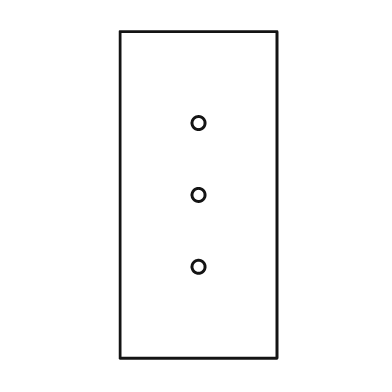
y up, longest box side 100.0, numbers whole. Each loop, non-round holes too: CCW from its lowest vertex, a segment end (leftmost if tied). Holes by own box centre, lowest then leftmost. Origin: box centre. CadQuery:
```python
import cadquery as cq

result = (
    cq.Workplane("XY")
    .moveTo(-24.0, -50.0)
    .lineTo(24.0, -50.0)
    .lineTo(24.0, 50.0)
    .lineTo(-24.0, 50.0)
    .close()
    .moveTo(0.0, -22.0)
    .circle(2.0)
    .moveTo(0.0, 0.0)
    .circle(2.0)
    .moveTo(0.0, 22.0)
    .circle(2.0)
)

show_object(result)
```